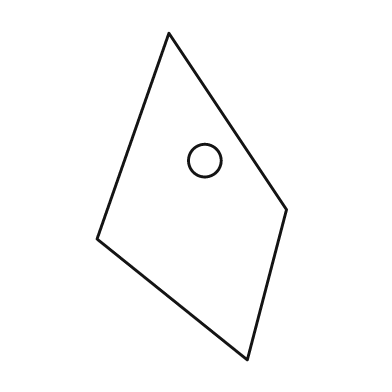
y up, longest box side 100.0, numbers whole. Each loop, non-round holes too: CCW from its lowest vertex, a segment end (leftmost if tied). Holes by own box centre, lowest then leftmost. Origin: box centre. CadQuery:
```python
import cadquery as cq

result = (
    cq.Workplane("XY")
    .moveTo(17.0, -50.0)
    .lineTo(29.0, -4.0)
    .lineTo(-7.0, 50.0)
    .lineTo(-29.0, -13.0)
    .close()
    .moveTo(4.0, 11.0)
    .circle(5.0)
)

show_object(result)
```